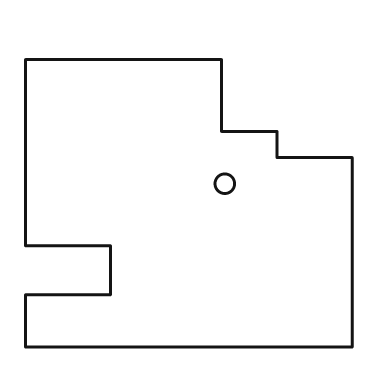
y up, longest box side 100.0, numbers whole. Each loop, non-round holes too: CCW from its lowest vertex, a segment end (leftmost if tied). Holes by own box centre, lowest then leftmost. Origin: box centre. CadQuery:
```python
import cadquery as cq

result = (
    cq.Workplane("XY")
    .moveTo(-50.0, -44.0)
    .lineTo(50.0, -44.0)
    .lineTo(50.0, 14.0)
    .lineTo(27.0, 14.0)
    .lineTo(27.0, 22.0)
    .lineTo(10.0, 22.0)
    .lineTo(10.0, 44.0)
    .lineTo(-50.0, 44.0)
    .lineTo(-50.0, -13.0)
    .lineTo(-24.0, -13.0)
    .lineTo(-24.0, -28.0)
    .lineTo(-50.0, -28.0)
    .close()
    .moveTo(11.0, 6.0)
    .circle(3.0)
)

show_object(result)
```